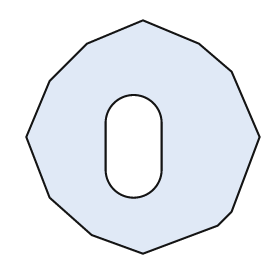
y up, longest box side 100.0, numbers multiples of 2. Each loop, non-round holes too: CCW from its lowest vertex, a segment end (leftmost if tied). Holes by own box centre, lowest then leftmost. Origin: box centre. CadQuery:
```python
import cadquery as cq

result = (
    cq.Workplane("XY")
    .moveTo(0.0, -50.0)
    .lineTo(32.0, -38.0)
    .lineTo(38.0, -32.0)
    .lineTo(50.0, 0.0)
    .lineTo(38.0, 28.0)
    .lineTo(24.0, 40.0)
    .lineTo(0.0, 50.0)
    .lineTo(-24.0, 40.0)
    .lineTo(-40.0, 24.0)
    .lineTo(-50.0, 0.0)
    .lineTo(-40.0, -26.0)
    .lineTo(-22.0, -42.0)
    .close()
    .moveTo(-16.0, -14.0)
    .threePointArc((-4.0, -26.0), (8.0, -14.0))
    .lineTo(8.0, 6.0)
    .threePointArc((-4.0, 18.0), (-16.0, 6.0))
    .close()
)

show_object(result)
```